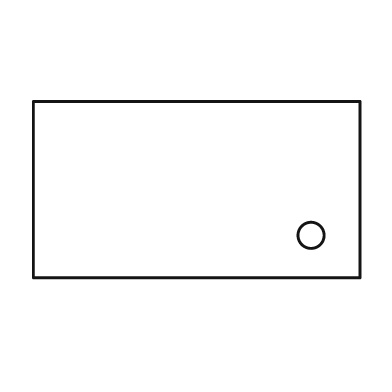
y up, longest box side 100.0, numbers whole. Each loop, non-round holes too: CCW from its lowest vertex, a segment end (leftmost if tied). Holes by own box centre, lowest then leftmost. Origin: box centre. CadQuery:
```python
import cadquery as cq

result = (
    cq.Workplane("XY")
    .moveTo(-50.0, -27.0)
    .lineTo(50.0, -27.0)
    .lineTo(50.0, 27.0)
    .lineTo(-50.0, 27.0)
    .close()
    .moveTo(35.0, -14.0)
    .circle(4.0)
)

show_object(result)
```